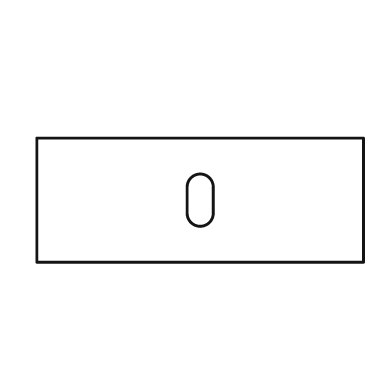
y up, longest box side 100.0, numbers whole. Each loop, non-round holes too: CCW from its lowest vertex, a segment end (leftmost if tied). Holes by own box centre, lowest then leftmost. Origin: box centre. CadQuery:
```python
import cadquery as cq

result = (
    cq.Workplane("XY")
    .moveTo(-50.0, -19.0)
    .lineTo(50.0, -19.0)
    .lineTo(50.0, 19.0)
    .lineTo(-50.0, 19.0)
    .close()
    .moveTo(-4.0, -4.0)
    .threePointArc((0.0, -8.0), (4.0, -4.0))
    .lineTo(4.0, 4.0)
    .threePointArc((0.0, 8.0), (-4.0, 4.0))
    .close()
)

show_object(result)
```